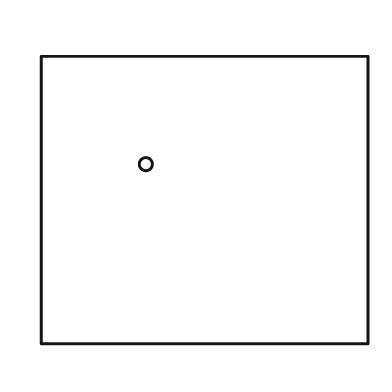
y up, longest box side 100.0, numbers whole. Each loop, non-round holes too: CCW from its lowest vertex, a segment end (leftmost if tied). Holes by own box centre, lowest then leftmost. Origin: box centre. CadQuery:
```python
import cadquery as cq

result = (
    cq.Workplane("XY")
    .moveTo(-50.0, -44.0)
    .lineTo(50.0, -44.0)
    .lineTo(50.0, 44.0)
    .lineTo(-50.0, 44.0)
    .close()
    .moveTo(-18.0, 11.0)
    .circle(2.0)
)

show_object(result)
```